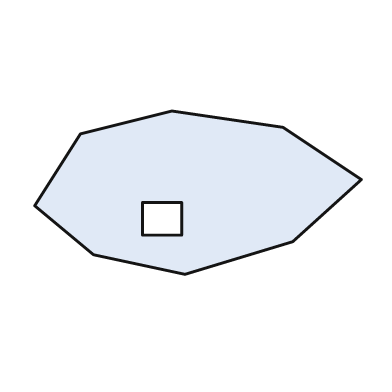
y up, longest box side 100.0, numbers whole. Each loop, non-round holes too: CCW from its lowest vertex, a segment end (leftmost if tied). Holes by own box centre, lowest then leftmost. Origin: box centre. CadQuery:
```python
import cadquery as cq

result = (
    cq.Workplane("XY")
    .moveTo(-4.0, -25.0)
    .lineTo(29.0, -15.0)
    .lineTo(50.0, 4.0)
    .lineTo(26.0, 20.0)
    .lineTo(-8.0, 25.0)
    .lineTo(-36.0, 18.0)
    .lineTo(-50.0, -4.0)
    .lineTo(-32.0, -19.0)
    .close()
    .moveTo(-17.0, -13.0)
    .lineTo(-5.0, -13.0)
    .lineTo(-5.0, -3.0)
    .lineTo(-17.0, -3.0)
    .close()
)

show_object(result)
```